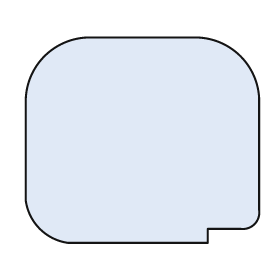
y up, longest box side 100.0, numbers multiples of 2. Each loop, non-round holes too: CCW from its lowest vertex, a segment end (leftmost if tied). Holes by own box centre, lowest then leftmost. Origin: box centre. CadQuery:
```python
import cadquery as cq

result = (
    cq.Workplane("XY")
    .moveTo(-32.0, -44.0)
    .lineTo(28.0, -44.0)
    .lineTo(28.0, -38.0)
    .lineTo(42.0, -38.0)
    .threePointArc((48.0, -36.0), (50.0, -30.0))
    .lineTo(50.0, 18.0)
    .threePointArc((42.0, 36.0), (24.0, 44.0))
    .lineTo(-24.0, 44.0)
    .threePointArc((-42.0, 36.0), (-50.0, 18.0))
    .lineTo(-50.0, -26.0)
    .threePointArc((-44.0, -38.0), (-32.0, -44.0))
    .close()
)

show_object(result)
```